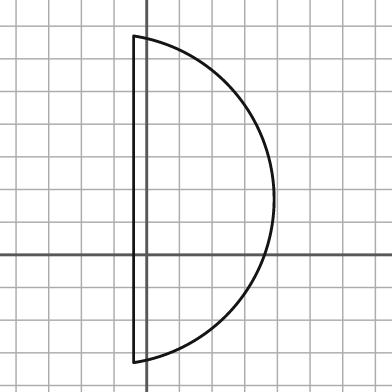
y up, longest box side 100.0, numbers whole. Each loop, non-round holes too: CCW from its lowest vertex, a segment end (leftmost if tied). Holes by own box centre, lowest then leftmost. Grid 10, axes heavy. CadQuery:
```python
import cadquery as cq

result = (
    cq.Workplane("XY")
    .moveTo(-4.0, -33.0)
    .threePointArc((39.0, 17.0), (-4.0, 67.0))
    .close()
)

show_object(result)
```